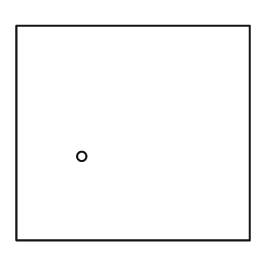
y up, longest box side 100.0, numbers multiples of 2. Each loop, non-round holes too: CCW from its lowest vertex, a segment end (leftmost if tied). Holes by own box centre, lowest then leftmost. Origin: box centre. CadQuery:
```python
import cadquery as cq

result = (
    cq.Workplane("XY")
    .moveTo(-50.0, -46.0)
    .lineTo(50.0, -46.0)
    .lineTo(50.0, 46.0)
    .lineTo(-50.0, 46.0)
    .close()
    .moveTo(-22.0, -10.0)
    .circle(2.0)
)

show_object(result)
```